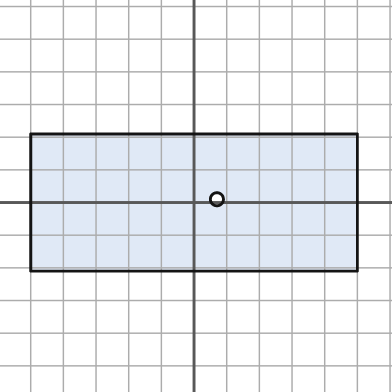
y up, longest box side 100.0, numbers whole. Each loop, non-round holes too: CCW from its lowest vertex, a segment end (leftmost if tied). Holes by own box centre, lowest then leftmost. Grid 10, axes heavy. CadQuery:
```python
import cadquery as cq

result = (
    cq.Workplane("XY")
    .moveTo(-50.0, -21.0)
    .lineTo(50.0, -21.0)
    .lineTo(50.0, 21.0)
    .lineTo(-50.0, 21.0)
    .close()
    .moveTo(7.0, 1.0)
    .circle(2.0)
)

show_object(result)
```